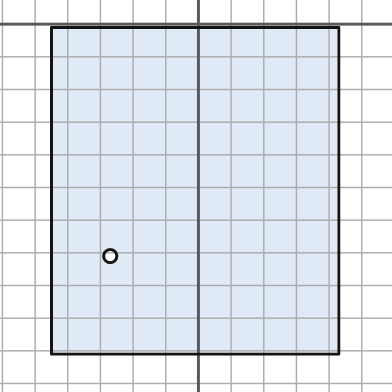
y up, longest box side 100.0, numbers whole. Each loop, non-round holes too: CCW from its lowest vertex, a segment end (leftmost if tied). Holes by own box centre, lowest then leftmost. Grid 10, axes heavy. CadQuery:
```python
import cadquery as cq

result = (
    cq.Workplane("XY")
    .moveTo(-45.0, -101.0)
    .lineTo(43.0, -101.0)
    .lineTo(43.0, -1.0)
    .lineTo(-45.0, -1.0)
    .close()
    .moveTo(-27.0, -71.0)
    .circle(2.0)
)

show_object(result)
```